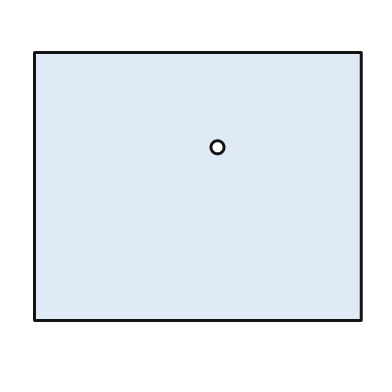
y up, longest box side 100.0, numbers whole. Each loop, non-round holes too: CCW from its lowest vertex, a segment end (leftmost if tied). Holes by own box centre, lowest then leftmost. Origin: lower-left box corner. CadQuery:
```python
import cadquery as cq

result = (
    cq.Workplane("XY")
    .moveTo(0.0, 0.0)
    .lineTo(100.0, 0.0)
    .lineTo(100.0, 82.0)
    .lineTo(0.0, 82.0)
    .close()
    .moveTo(56.0, 53.0)
    .circle(2.0)
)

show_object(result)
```